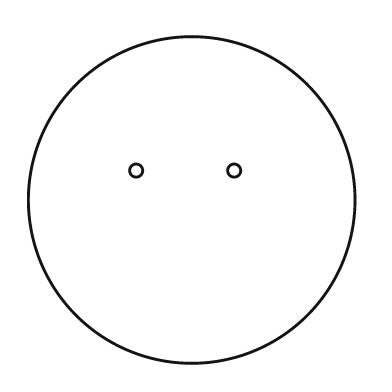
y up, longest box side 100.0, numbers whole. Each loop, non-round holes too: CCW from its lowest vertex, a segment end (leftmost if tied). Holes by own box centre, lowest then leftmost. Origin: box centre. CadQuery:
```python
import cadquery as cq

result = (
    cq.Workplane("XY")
    .moveTo(0.0, 0.0)
    .circle(50.0)
    .moveTo(-17.0, 9.0)
    .circle(2.0)
    .moveTo(13.0, 9.0)
    .circle(2.0)
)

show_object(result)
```